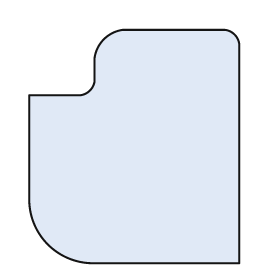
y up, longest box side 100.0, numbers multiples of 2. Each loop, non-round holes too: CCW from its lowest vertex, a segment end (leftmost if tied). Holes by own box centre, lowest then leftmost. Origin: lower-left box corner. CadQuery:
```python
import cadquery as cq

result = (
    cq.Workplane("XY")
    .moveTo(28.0, 0.0)
    .lineTo(90.0, 0.0)
    .lineTo(90.0, 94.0)
    .threePointArc((88.0, 98.0), (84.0, 100.0))
    .lineTo(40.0, 100.0)
    .threePointArc((32.0, 96.0), (28.0, 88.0))
    .lineTo(28.0, 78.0)
    .threePointArc((26.0, 74.0), (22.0, 72.0))
    .lineTo(0.0, 72.0)
    .lineTo(0.0, 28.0)
    .threePointArc((8.0, 8.0), (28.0, 0.0))
    .close()
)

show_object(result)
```